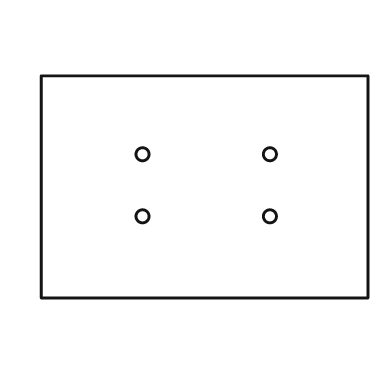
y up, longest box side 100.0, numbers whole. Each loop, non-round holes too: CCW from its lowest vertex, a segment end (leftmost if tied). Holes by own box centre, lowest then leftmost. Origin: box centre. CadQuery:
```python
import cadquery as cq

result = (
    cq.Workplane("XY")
    .moveTo(-50.0, -34.0)
    .lineTo(50.0, -34.0)
    .lineTo(50.0, 34.0)
    .lineTo(-50.0, 34.0)
    .close()
    .moveTo(-19.0, -9.0)
    .circle(2.0)
    .moveTo(20.0, -9.0)
    .circle(2.0)
    .moveTo(-19.0, 10.0)
    .circle(2.0)
    .moveTo(20.0, 10.0)
    .circle(2.0)
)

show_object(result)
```